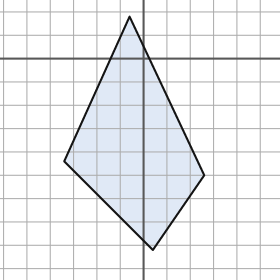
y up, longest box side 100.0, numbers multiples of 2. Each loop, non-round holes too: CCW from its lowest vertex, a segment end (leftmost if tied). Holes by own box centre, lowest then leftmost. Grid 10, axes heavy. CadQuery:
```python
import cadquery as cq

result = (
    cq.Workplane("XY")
    .moveTo(4.0, -82.0)
    .lineTo(26.0, -50.0)
    .lineTo(-6.0, 18.0)
    .lineTo(-34.0, -44.0)
    .close()
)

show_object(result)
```